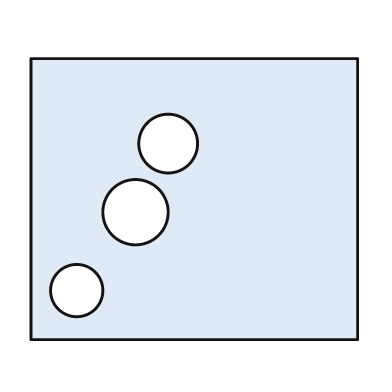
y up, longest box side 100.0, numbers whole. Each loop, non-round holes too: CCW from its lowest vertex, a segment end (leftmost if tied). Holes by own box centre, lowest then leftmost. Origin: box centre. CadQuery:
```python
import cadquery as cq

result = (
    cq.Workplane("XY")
    .moveTo(-50.0, -43.0)
    .lineTo(50.0, -43.0)
    .lineTo(50.0, 43.0)
    .lineTo(-50.0, 43.0)
    .close()
    .moveTo(-36.0, -28.0)
    .circle(8.0)
    .moveTo(-18.0, -4.0)
    .circle(10.0)
    .moveTo(-8.0, 17.0)
    .circle(9.0)
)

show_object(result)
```